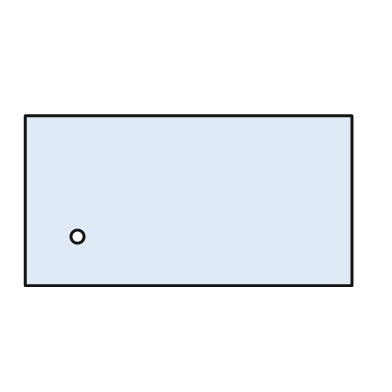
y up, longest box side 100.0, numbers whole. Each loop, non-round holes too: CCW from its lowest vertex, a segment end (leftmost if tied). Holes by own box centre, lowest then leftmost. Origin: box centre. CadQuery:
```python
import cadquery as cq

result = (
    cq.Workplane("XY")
    .moveTo(-50.0, -26.0)
    .lineTo(50.0, -26.0)
    .lineTo(50.0, 26.0)
    .lineTo(-50.0, 26.0)
    .close()
    .moveTo(-34.0, -11.0)
    .circle(2.0)
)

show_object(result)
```